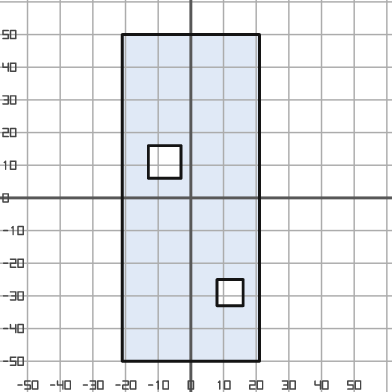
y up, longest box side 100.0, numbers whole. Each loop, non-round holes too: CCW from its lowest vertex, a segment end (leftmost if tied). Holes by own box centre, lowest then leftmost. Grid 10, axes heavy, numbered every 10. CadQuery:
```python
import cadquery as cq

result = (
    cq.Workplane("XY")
    .moveTo(-21.0, -50.0)
    .lineTo(21.0, -50.0)
    .lineTo(21.0, 50.0)
    .lineTo(-21.0, 50.0)
    .close()
    .moveTo(8.0, -33.0)
    .lineTo(16.0, -33.0)
    .lineTo(16.0, -25.0)
    .lineTo(8.0, -25.0)
    .close()
    .moveTo(-13.0, 6.0)
    .lineTo(-3.0, 6.0)
    .lineTo(-3.0, 16.0)
    .lineTo(-13.0, 16.0)
    .close()
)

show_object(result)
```